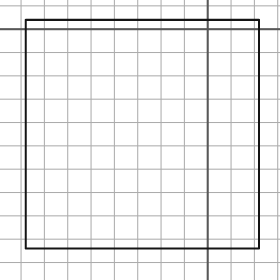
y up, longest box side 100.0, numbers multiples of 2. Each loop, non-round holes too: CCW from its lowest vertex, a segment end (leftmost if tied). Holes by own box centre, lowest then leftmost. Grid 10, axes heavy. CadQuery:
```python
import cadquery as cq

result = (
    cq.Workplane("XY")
    .moveTo(-78.0, -94.0)
    .lineTo(22.0, -94.0)
    .lineTo(22.0, 4.0)
    .lineTo(-78.0, 4.0)
    .close()
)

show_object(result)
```